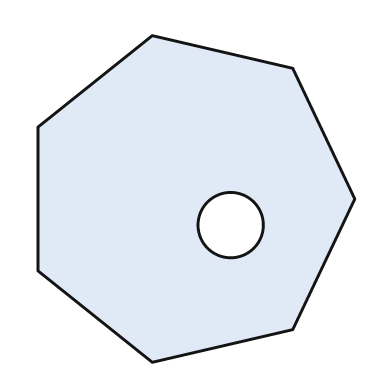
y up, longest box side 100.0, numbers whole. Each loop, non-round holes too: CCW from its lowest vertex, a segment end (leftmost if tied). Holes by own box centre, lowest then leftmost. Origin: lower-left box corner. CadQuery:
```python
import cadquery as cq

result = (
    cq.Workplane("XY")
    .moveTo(35.0, 0.0)
    .lineTo(78.0, 10.0)
    .lineTo(97.0, 50.0)
    .lineTo(78.0, 90.0)
    .lineTo(35.0, 100.0)
    .lineTo(0.0, 72.0)
    .lineTo(0.0, 28.0)
    .close()
    .moveTo(59.0, 42.0)
    .circle(10.0)
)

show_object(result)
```